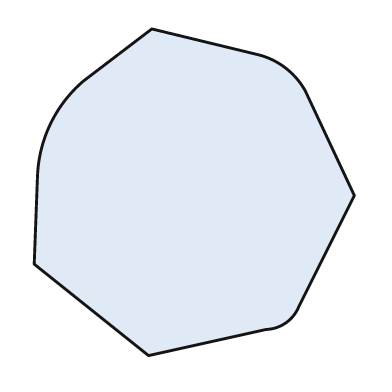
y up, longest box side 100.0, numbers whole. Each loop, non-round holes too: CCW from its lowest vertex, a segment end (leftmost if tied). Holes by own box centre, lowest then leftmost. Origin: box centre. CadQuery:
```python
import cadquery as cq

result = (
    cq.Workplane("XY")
    .moveTo(-14.0, -50.0)
    .lineTo(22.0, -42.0)
    .threePointArc((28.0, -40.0), (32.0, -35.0))
    .lineTo(49.0, -1.0)
    .lineTo(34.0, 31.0)
    .threePointArc((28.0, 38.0), (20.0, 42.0))
    .lineTo(-13.0, 50.0)
    .lineTo(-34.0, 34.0)
    .threePointArc((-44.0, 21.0), (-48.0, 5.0))
    .lineTo(-49.0, -22.0)
    .close()
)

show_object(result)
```